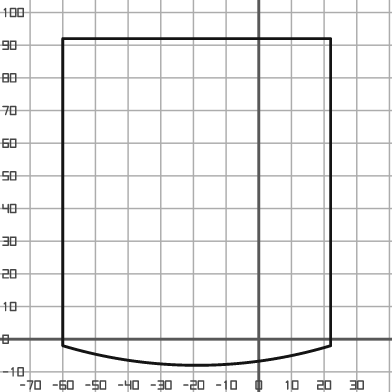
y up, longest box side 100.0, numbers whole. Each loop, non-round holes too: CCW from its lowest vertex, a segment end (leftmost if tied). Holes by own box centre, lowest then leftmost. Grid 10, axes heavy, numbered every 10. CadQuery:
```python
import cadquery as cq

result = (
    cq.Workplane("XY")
    .moveTo(-60.0, -2.0)
    .threePointArc((-19.0, -8.0), (22.0, -2.0))
    .lineTo(22.0, 92.0)
    .lineTo(-60.0, 92.0)
    .close()
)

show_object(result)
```